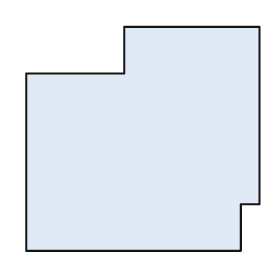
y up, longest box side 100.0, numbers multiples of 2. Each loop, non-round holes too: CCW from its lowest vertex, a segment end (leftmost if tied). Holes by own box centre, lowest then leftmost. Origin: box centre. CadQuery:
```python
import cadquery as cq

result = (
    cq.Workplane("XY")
    .moveTo(-50.0, -48.0)
    .lineTo(42.0, -48.0)
    .lineTo(42.0, -28.0)
    .lineTo(50.0, -28.0)
    .lineTo(50.0, 48.0)
    .lineTo(-8.0, 48.0)
    .lineTo(-8.0, 28.0)
    .lineTo(-50.0, 28.0)
    .close()
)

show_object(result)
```